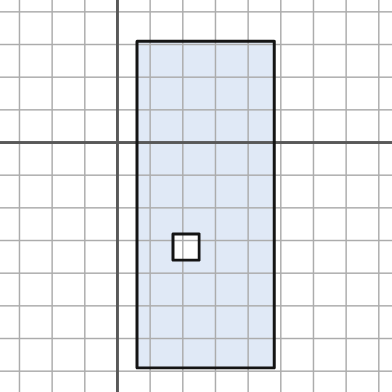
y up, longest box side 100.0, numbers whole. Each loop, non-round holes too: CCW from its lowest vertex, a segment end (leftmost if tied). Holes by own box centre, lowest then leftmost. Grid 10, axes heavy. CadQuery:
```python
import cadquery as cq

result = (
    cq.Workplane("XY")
    .moveTo(6.0, -69.0)
    .lineTo(48.0, -69.0)
    .lineTo(48.0, 31.0)
    .lineTo(6.0, 31.0)
    .close()
    .moveTo(17.0, -36.0)
    .lineTo(25.0, -36.0)
    .lineTo(25.0, -28.0)
    .lineTo(17.0, -28.0)
    .close()
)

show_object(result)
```